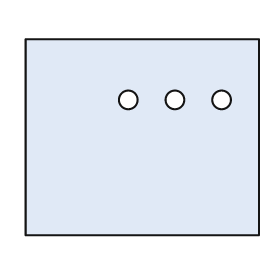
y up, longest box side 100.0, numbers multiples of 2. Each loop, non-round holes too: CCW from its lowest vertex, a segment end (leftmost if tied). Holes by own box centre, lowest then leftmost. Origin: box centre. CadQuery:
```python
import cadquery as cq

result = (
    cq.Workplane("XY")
    .moveTo(-50.0, -42.0)
    .lineTo(50.0, -42.0)
    .lineTo(50.0, 42.0)
    .lineTo(-50.0, 42.0)
    .close()
    .moveTo(-6.0, 16.0)
    .circle(4.0)
    .moveTo(14.0, 16.0)
    .circle(4.0)
    .moveTo(34.0, 16.0)
    .circle(4.0)
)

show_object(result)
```